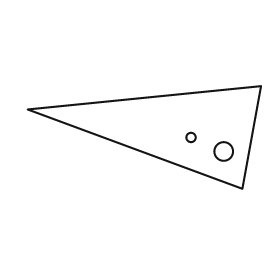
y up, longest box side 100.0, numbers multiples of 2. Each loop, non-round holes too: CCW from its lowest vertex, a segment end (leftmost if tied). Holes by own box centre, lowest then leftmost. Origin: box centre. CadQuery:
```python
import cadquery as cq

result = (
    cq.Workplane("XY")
    .moveTo(42.0, -22.0)
    .lineTo(50.0, 22.0)
    .lineTo(-50.0, 12.0)
    .close()
    .moveTo(34.0, -6.0)
    .circle(4.0)
    .moveTo(20.0, 0.0)
    .circle(2.0)
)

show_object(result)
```